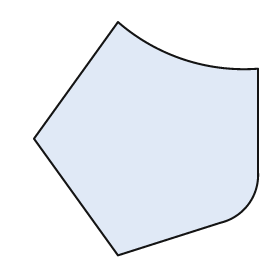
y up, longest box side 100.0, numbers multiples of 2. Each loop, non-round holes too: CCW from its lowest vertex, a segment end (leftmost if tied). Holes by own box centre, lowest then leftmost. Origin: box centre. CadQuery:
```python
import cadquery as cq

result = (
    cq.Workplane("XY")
    .moveTo(-12.0, -50.0)
    .lineTo(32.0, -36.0)
    .threePointArc((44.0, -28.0), (48.0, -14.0))
    .lineTo(48.0, 30.0)
    .threePointArc((16.0, 34.0), (-12.0, 50.0))
    .lineTo(-48.0, 0.0)
    .close()
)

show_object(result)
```